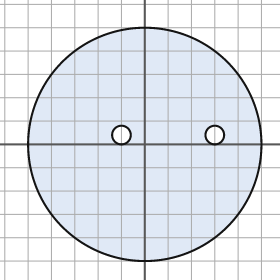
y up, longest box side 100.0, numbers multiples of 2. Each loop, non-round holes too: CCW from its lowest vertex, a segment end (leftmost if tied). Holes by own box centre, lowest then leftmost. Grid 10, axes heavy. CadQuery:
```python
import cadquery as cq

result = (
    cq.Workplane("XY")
    .moveTo(0.0, 0.0)
    .circle(50.0)
    .moveTo(-10.0, 4.0)
    .circle(4.0)
    .moveTo(30.0, 4.0)
    .circle(4.0)
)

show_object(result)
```